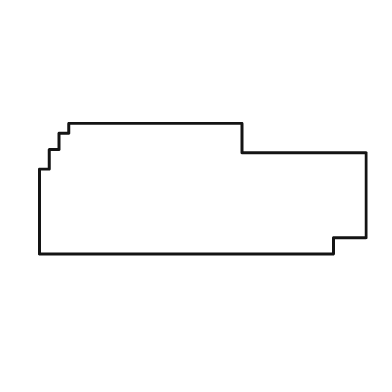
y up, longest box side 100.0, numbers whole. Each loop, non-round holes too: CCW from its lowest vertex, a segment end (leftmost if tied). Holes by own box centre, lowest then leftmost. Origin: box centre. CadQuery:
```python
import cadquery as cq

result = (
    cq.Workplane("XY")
    .moveTo(-50.0, -20.0)
    .lineTo(40.0, -20.0)
    .lineTo(40.0, -15.0)
    .lineTo(50.0, -15.0)
    .lineTo(50.0, 11.0)
    .lineTo(12.0, 11.0)
    .lineTo(12.0, 20.0)
    .lineTo(-41.0, 20.0)
    .lineTo(-41.0, 17.0)
    .lineTo(-44.0, 17.0)
    .lineTo(-44.0, 12.0)
    .lineTo(-47.0, 12.0)
    .lineTo(-47.0, 6.0)
    .lineTo(-50.0, 6.0)
    .close()
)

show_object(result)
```